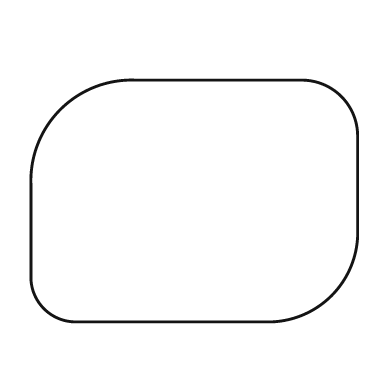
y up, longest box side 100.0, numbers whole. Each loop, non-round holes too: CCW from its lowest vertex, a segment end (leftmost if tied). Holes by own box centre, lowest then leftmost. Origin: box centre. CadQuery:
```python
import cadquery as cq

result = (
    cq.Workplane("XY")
    .moveTo(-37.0, -37.0)
    .lineTo(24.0, -37.0)
    .threePointArc((42.0, -29.0), (50.0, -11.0))
    .lineTo(50.0, 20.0)
    .threePointArc((45.0, 32.0), (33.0, 37.0))
    .lineTo(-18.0, 37.0)
    .threePointArc((-41.0, 28.0), (-50.0, 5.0))
    .lineTo(-50.0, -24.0)
    .threePointArc((-46.0, -33.0), (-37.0, -37.0))
    .close()
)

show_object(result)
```